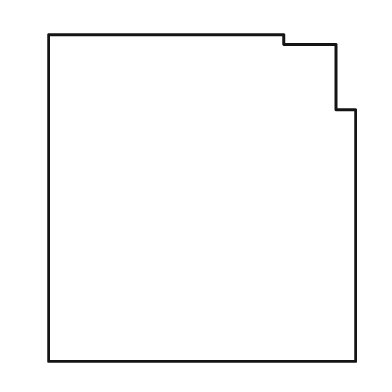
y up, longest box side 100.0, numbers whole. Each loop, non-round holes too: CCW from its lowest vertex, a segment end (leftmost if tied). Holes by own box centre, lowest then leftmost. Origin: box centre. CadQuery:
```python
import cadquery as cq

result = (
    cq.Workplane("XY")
    .moveTo(-47.0, -50.0)
    .lineTo(47.0, -50.0)
    .lineTo(47.0, 27.0)
    .lineTo(41.0, 27.0)
    .lineTo(41.0, 47.0)
    .lineTo(25.0, 47.0)
    .lineTo(25.0, 50.0)
    .lineTo(-47.0, 50.0)
    .close()
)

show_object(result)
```